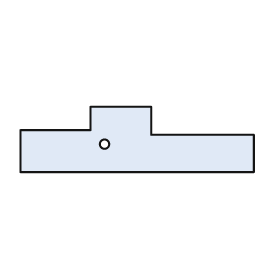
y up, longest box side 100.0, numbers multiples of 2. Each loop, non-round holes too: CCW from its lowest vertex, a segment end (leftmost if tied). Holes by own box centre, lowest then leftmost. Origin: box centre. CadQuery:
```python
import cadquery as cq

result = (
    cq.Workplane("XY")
    .moveTo(-50.0, -14.0)
    .lineTo(50.0, -14.0)
    .lineTo(50.0, 2.0)
    .lineTo(6.0, 2.0)
    .lineTo(6.0, 14.0)
    .lineTo(-20.0, 14.0)
    .lineTo(-20.0, 4.0)
    .lineTo(-50.0, 4.0)
    .close()
    .moveTo(-14.0, -2.0)
    .circle(2.0)
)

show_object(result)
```